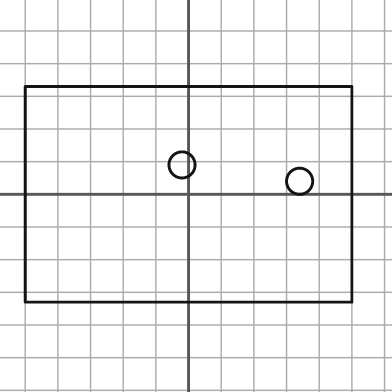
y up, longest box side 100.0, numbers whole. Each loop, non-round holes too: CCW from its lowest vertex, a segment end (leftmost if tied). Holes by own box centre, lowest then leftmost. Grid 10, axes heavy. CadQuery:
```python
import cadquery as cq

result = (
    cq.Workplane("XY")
    .moveTo(-50.0, -33.0)
    .lineTo(50.0, -33.0)
    .lineTo(50.0, 33.0)
    .lineTo(-50.0, 33.0)
    .close()
    .moveTo(34.0, 4.0)
    .circle(4.0)
    .moveTo(-2.0, 9.0)
    .circle(4.0)
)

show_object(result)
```